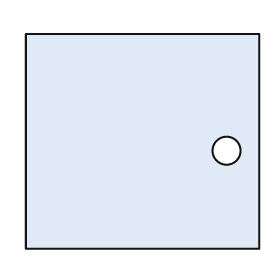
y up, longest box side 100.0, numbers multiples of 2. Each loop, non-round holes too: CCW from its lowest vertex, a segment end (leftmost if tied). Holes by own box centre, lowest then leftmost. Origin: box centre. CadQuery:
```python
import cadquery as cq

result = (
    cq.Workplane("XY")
    .moveTo(-50.0, -46.0)
    .lineTo(50.0, -46.0)
    .lineTo(50.0, 46.0)
    .lineTo(-50.0, 46.0)
    .close()
    .moveTo(36.0, -4.0)
    .circle(6.0)
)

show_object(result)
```